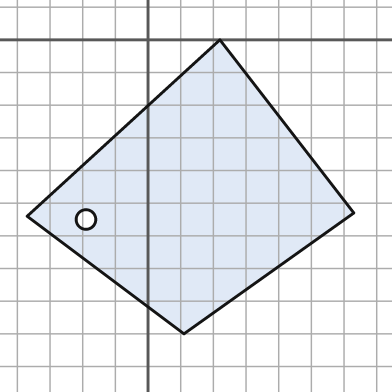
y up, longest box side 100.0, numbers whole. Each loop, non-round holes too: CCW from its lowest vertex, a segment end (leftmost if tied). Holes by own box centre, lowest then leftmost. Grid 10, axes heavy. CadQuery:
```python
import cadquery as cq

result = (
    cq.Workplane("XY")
    .moveTo(11.0, -90.0)
    .lineTo(63.0, -53.0)
    .lineTo(22.0, 0.0)
    .lineTo(-37.0, -54.0)
    .close()
    .moveTo(-19.0, -55.0)
    .circle(3.0)
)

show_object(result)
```